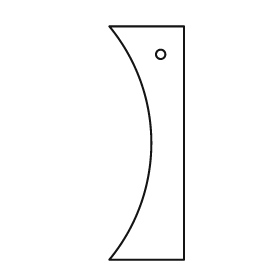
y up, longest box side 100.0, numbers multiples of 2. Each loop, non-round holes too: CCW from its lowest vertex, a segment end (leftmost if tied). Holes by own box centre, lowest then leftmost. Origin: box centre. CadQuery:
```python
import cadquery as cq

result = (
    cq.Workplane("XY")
    .moveTo(-16.0, -50.0)
    .lineTo(16.0, -50.0)
    .lineTo(16.0, 50.0)
    .lineTo(-16.0, 50.0)
    .threePointArc((2.0, 0.0), (-16.0, -50.0))
    .close()
    .moveTo(6.0, 38.0)
    .circle(2.0)
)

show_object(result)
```